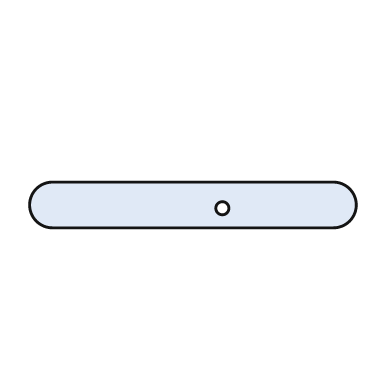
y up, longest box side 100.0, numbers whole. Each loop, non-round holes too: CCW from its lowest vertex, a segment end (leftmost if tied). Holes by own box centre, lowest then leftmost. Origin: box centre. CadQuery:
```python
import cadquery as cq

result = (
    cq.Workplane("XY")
    .moveTo(-43.0, -7.0)
    .lineTo(43.0, -7.0)
    .threePointArc((50.0, 0.0), (43.0, 7.0))
    .lineTo(-43.0, 7.0)
    .threePointArc((-50.0, 0.0), (-43.0, -7.0))
    .close()
    .moveTo(9.0, -1.0)
    .circle(2.0)
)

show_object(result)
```